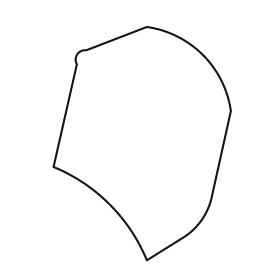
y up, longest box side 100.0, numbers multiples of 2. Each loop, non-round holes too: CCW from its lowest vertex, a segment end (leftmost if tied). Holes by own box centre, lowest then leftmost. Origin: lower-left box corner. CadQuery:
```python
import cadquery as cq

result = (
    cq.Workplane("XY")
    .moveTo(40.0, 0.0)
    .lineTo(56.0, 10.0)
    .threePointArc((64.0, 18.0), (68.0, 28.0))
    .lineTo(76.0, 64.0)
    .threePointArc((64.0, 88.0), (40.0, 100.0))
    .lineTo(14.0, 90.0)
    .threePointArc((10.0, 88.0), (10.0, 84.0))
    .lineTo(0.0, 40.0)
    .threePointArc((24.0, 24.0), (40.0, 0.0))
    .close()
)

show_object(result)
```